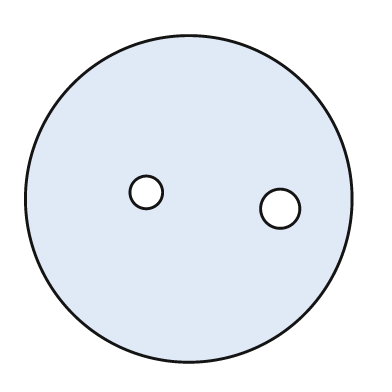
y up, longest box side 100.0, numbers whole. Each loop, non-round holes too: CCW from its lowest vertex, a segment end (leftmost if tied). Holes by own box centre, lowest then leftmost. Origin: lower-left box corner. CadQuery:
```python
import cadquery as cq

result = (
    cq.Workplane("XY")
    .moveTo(50.0, 50.0)
    .circle(50.0)
    .moveTo(78.0, 47.0)
    .circle(6.0)
    .moveTo(37.0, 52.0)
    .circle(5.0)
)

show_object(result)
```